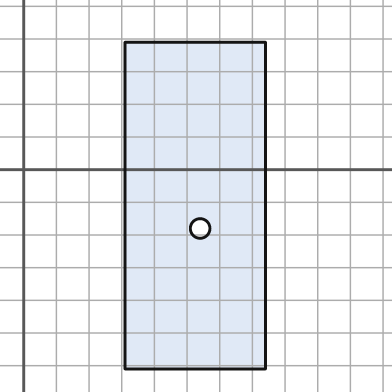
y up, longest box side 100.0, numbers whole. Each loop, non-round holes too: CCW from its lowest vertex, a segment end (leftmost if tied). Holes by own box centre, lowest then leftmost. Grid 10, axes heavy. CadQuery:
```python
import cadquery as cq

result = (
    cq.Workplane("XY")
    .moveTo(31.0, -61.0)
    .lineTo(74.0, -61.0)
    .lineTo(74.0, 39.0)
    .lineTo(31.0, 39.0)
    .close()
    .moveTo(54.0, -18.0)
    .circle(3.0)
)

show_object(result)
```